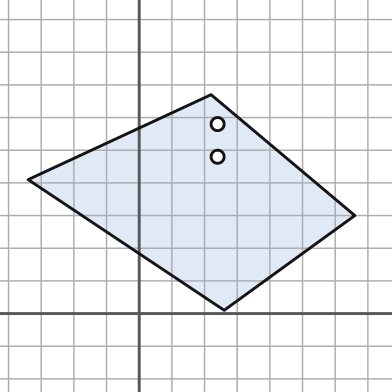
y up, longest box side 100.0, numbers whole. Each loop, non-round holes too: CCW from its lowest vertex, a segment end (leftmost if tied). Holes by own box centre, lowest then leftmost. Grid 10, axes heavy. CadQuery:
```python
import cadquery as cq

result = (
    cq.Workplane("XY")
    .moveTo(26.0, 1.0)
    .lineTo(66.0, 30.0)
    .lineTo(22.0, 67.0)
    .lineTo(-34.0, 41.0)
    .close()
    .moveTo(24.0, 48.0)
    .circle(2.0)
    .moveTo(24.0, 58.0)
    .circle(2.0)
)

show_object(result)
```